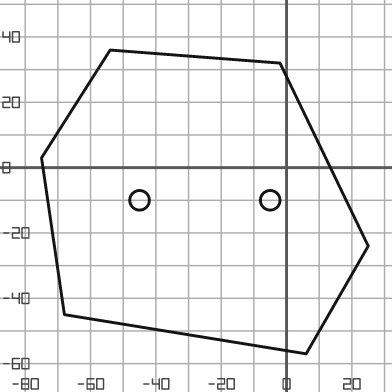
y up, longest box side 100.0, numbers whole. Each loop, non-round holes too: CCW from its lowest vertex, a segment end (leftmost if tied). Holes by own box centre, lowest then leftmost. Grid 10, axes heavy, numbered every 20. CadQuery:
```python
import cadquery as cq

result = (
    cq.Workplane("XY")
    .moveTo(6.0, -57.0)
    .lineTo(25.0, -24.0)
    .lineTo(-2.0, 32.0)
    .lineTo(-54.0, 36.0)
    .lineTo(-75.0, 3.0)
    .lineTo(-68.0, -45.0)
    .close()
    .moveTo(-45.0, -10.0)
    .circle(3.0)
    .moveTo(-5.0, -10.0)
    .circle(3.0)
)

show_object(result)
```